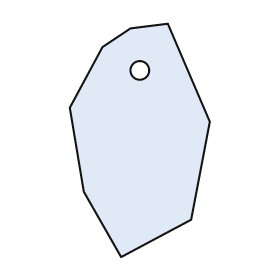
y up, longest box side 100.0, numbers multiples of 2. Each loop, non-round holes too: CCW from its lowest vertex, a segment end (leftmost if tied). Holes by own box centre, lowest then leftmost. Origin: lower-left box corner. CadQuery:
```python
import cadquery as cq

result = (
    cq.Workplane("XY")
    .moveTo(22.0, 0.0)
    .lineTo(52.0, 16.0)
    .lineTo(60.0, 58.0)
    .lineTo(42.0, 100.0)
    .lineTo(26.0, 98.0)
    .lineTo(14.0, 90.0)
    .lineTo(0.0, 64.0)
    .lineTo(6.0, 28.0)
    .close()
    .moveTo(30.0, 80.0)
    .circle(4.0)
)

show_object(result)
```